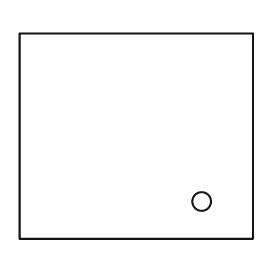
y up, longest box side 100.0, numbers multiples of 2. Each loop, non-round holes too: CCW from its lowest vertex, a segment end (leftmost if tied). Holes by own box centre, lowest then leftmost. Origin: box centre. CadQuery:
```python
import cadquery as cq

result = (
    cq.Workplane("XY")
    .moveTo(-50.0, -44.0)
    .lineTo(50.0, -44.0)
    .lineTo(50.0, 44.0)
    .lineTo(-50.0, 44.0)
    .close()
    .moveTo(28.0, -28.0)
    .circle(4.0)
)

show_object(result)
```